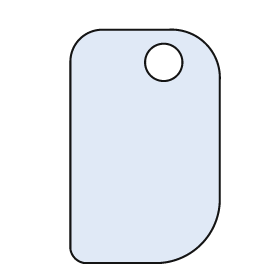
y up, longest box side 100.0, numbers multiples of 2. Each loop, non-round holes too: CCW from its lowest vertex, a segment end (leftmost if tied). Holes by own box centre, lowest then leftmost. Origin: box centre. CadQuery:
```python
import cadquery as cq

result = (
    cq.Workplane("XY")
    .moveTo(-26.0, -50.0)
    .lineTo(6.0, -50.0)
    .threePointArc((24.0, -42.0), (32.0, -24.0))
    .lineTo(32.0, 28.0)
    .threePointArc((26.0, 44.0), (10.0, 50.0))
    .lineTo(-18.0, 50.0)
    .threePointArc((-28.0, 46.0), (-32.0, 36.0))
    .lineTo(-32.0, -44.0)
    .threePointArc((-30.0, -48.0), (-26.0, -50.0))
    .close()
    .moveTo(8.0, 36.0)
    .circle(8.0)
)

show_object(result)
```